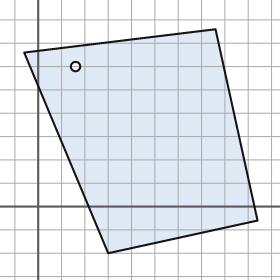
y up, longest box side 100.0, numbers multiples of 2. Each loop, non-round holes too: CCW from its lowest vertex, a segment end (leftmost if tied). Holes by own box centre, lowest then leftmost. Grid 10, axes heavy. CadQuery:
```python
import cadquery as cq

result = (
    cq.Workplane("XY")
    .moveTo(30.0, -20.0)
    .lineTo(94.0, -6.0)
    .lineTo(76.0, 76.0)
    .lineTo(-6.0, 66.0)
    .close()
    .moveTo(16.0, 60.0)
    .circle(2.0)
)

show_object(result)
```